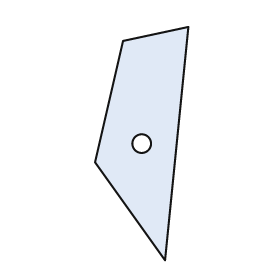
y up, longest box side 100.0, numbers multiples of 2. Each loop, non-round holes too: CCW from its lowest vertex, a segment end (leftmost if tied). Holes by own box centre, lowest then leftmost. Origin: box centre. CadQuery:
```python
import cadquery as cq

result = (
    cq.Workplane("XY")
    .moveTo(10.0, -50.0)
    .lineTo(20.0, 50.0)
    .lineTo(-8.0, 44.0)
    .lineTo(-20.0, -8.0)
    .close()
    .moveTo(0.0, 0.0)
    .circle(4.0)
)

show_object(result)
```